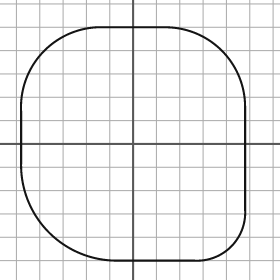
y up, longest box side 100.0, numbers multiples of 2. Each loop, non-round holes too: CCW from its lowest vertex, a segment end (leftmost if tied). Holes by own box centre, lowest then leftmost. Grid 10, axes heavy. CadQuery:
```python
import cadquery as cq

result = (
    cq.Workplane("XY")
    .moveTo(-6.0, -50.0)
    .lineTo(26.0, -50.0)
    .threePointArc((42.0, -44.0), (48.0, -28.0))
    .lineTo(48.0, 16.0)
    .threePointArc((38.0, 40.0), (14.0, 50.0))
    .lineTo(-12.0, 50.0)
    .threePointArc((-38.0, 40.0), (-48.0, 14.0))
    .lineTo(-48.0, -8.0)
    .threePointArc((-36.0, -38.0), (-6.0, -50.0))
    .close()
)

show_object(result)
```